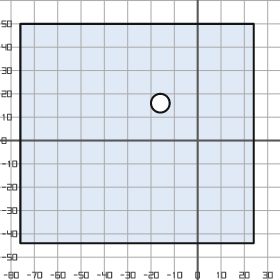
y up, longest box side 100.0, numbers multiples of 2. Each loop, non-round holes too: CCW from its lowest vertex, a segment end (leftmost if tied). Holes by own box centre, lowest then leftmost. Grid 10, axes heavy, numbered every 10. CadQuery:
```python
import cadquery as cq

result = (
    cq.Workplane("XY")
    .moveTo(-76.0, -44.0)
    .lineTo(24.0, -44.0)
    .lineTo(24.0, 50.0)
    .lineTo(-76.0, 50.0)
    .close()
    .moveTo(-16.0, 16.0)
    .circle(4.0)
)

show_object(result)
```